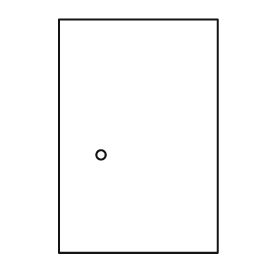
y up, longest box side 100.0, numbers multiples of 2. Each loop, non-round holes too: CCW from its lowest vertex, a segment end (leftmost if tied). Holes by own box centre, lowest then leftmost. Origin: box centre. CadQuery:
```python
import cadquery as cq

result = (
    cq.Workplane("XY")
    .moveTo(-34.0, -50.0)
    .lineTo(34.0, -50.0)
    .lineTo(34.0, 50.0)
    .lineTo(-34.0, 50.0)
    .close()
    .moveTo(-16.0, -8.0)
    .circle(2.0)
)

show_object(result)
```